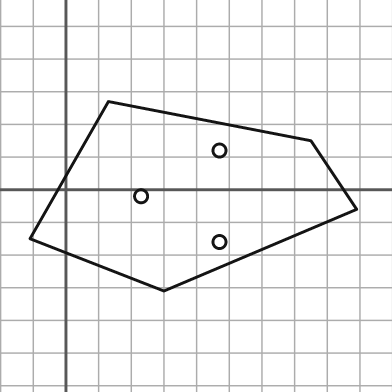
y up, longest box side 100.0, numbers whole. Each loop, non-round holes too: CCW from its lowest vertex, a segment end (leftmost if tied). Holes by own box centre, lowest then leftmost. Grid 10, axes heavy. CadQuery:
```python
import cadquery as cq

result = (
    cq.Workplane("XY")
    .moveTo(30.0, -31.0)
    .lineTo(89.0, -6.0)
    .lineTo(75.0, 15.0)
    .lineTo(13.0, 27.0)
    .lineTo(-11.0, -15.0)
    .close()
    .moveTo(47.0, -16.0)
    .circle(2.0)
    .moveTo(23.0, -2.0)
    .circle(2.0)
    .moveTo(47.0, 12.0)
    .circle(2.0)
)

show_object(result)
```